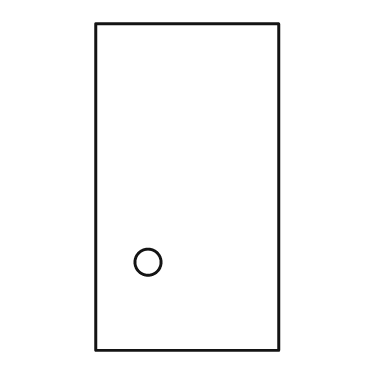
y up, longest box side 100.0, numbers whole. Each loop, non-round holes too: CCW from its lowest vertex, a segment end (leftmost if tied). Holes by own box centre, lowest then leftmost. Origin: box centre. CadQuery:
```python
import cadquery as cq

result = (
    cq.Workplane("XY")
    .moveTo(-28.0, -50.0)
    .lineTo(28.0, -50.0)
    .lineTo(28.0, 50.0)
    .lineTo(-28.0, 50.0)
    .close()
    .moveTo(-12.0, -23.0)
    .circle(4.0)
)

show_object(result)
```